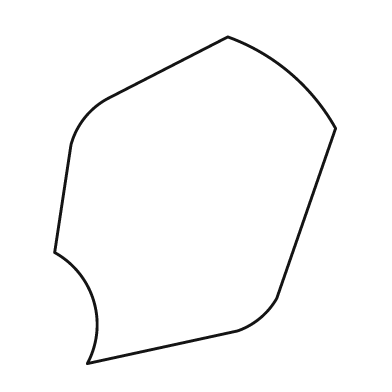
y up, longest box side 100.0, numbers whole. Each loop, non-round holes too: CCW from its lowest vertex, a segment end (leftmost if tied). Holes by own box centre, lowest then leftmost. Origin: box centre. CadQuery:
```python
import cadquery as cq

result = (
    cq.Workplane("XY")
    .moveTo(-33.0, -50.0)
    .lineTo(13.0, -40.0)
    .threePointArc((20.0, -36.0), (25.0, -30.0))
    .lineTo(43.0, 22.0)
    .threePointArc((29.0, 39.0), (10.0, 50.0))
    .lineTo(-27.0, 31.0)
    .threePointArc((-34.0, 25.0), (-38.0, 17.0))
    .lineTo(-43.0, -16.0)
    .threePointArc((-31.0, -31.0), (-33.0, -50.0))
    .close()
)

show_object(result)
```